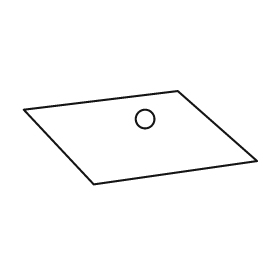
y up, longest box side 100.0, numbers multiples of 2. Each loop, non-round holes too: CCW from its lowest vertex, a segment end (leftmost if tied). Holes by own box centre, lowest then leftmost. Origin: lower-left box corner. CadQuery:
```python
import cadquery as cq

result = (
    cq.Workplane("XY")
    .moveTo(30.0, 0.0)
    .lineTo(100.0, 10.0)
    .lineTo(66.0, 40.0)
    .lineTo(0.0, 32.0)
    .close()
    .moveTo(52.0, 28.0)
    .circle(4.0)
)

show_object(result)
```